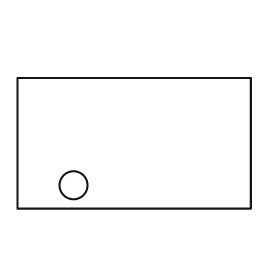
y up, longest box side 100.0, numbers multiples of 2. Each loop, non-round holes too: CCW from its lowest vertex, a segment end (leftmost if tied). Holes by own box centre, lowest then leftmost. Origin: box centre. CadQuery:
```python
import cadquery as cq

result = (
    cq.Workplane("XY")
    .moveTo(-50.0, -28.0)
    .lineTo(50.0, -28.0)
    .lineTo(50.0, 28.0)
    .lineTo(-50.0, 28.0)
    .close()
    .moveTo(-26.0, -18.0)
    .circle(6.0)
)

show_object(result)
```